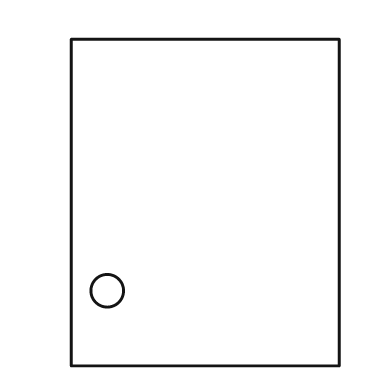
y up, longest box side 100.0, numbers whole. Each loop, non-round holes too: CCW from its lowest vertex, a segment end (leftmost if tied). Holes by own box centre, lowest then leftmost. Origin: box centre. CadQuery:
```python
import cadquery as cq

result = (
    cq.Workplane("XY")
    .moveTo(-41.0, -50.0)
    .lineTo(41.0, -50.0)
    .lineTo(41.0, 50.0)
    .lineTo(-41.0, 50.0)
    .close()
    .moveTo(-30.0, -27.0)
    .circle(5.0)
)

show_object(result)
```